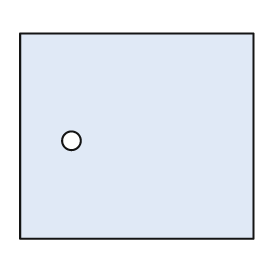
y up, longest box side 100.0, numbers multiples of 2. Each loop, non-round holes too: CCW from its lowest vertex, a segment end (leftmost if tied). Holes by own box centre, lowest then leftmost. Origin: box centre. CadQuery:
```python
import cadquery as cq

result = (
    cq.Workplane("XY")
    .moveTo(-50.0, -44.0)
    .lineTo(50.0, -44.0)
    .lineTo(50.0, 44.0)
    .lineTo(-50.0, 44.0)
    .close()
    .moveTo(-28.0, -2.0)
    .circle(4.0)
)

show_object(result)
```